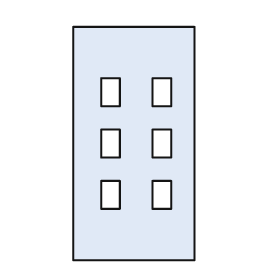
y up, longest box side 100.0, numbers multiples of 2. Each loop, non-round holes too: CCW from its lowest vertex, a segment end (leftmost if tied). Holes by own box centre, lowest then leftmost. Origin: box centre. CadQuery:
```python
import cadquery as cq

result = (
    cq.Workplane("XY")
    .moveTo(-26.0, -50.0)
    .lineTo(26.0, -50.0)
    .lineTo(26.0, 50.0)
    .lineTo(-26.0, 50.0)
    .close()
    .moveTo(-14.0, -28.0)
    .lineTo(-6.0, -28.0)
    .lineTo(-6.0, -16.0)
    .lineTo(-14.0, -16.0)
    .close()
    .moveTo(8.0, -28.0)
    .lineTo(16.0, -28.0)
    .lineTo(16.0, -16.0)
    .lineTo(8.0, -16.0)
    .close()
    .moveTo(-14.0, -6.0)
    .lineTo(-6.0, -6.0)
    .lineTo(-6.0, 6.0)
    .lineTo(-14.0, 6.0)
    .close()
    .moveTo(8.0, -6.0)
    .lineTo(16.0, -6.0)
    .lineTo(16.0, 6.0)
    .lineTo(8.0, 6.0)
    .close()
    .moveTo(-14.0, 16.0)
    .lineTo(-6.0, 16.0)
    .lineTo(-6.0, 28.0)
    .lineTo(-14.0, 28.0)
    .close()
    .moveTo(8.0, 16.0)
    .lineTo(16.0, 16.0)
    .lineTo(16.0, 28.0)
    .lineTo(8.0, 28.0)
    .close()
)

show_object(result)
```